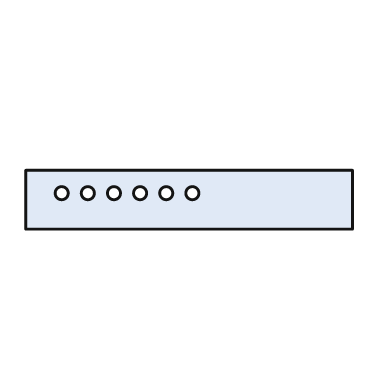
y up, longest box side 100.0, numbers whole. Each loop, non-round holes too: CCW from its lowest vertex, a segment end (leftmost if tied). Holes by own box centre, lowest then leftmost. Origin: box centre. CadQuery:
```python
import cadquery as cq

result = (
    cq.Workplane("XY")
    .moveTo(-50.0, -9.0)
    .lineTo(50.0, -9.0)
    .lineTo(50.0, 9.0)
    .lineTo(-50.0, 9.0)
    .close()
    .moveTo(-39.0, 2.0)
    .circle(2.0)
    .moveTo(-31.0, 2.0)
    .circle(2.0)
    .moveTo(-23.0, 2.0)
    .circle(2.0)
    .moveTo(-15.0, 2.0)
    .circle(2.0)
    .moveTo(-7.0, 2.0)
    .circle(2.0)
    .moveTo(1.0, 2.0)
    .circle(2.0)
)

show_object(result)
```